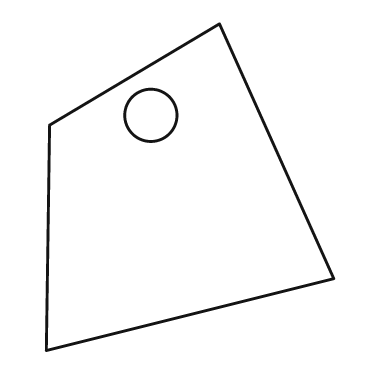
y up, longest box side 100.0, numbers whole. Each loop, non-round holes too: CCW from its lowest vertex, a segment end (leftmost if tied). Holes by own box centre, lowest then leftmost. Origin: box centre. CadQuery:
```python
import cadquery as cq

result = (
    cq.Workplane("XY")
    .moveTo(-44.0, -50.0)
    .lineTo(44.0, -28.0)
    .lineTo(9.0, 50.0)
    .lineTo(-43.0, 19.0)
    .close()
    .moveTo(-12.0, 22.0)
    .circle(8.0)
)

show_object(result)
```